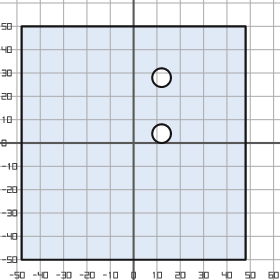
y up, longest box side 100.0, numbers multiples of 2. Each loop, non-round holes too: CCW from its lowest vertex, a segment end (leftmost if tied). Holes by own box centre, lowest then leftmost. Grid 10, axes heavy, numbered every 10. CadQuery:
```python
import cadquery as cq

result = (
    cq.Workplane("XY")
    .moveTo(-48.0, -50.0)
    .lineTo(48.0, -50.0)
    .lineTo(48.0, 50.0)
    .lineTo(-48.0, 50.0)
    .close()
    .moveTo(12.0, 4.0)
    .circle(4.0)
    .moveTo(12.0, 28.0)
    .circle(4.0)
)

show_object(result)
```